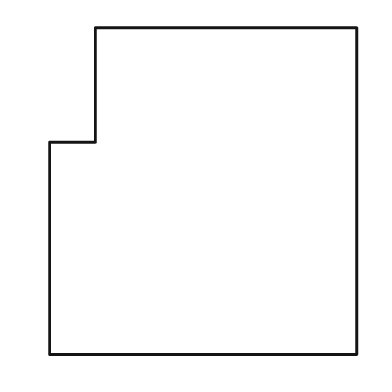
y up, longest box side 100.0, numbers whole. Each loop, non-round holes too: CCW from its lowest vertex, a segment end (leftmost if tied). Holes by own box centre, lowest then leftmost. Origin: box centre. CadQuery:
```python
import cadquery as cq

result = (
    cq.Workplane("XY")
    .moveTo(-47.0, -50.0)
    .lineTo(47.0, -50.0)
    .lineTo(47.0, 50.0)
    .lineTo(-33.0, 50.0)
    .lineTo(-33.0, 15.0)
    .lineTo(-47.0, 15.0)
    .close()
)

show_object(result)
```